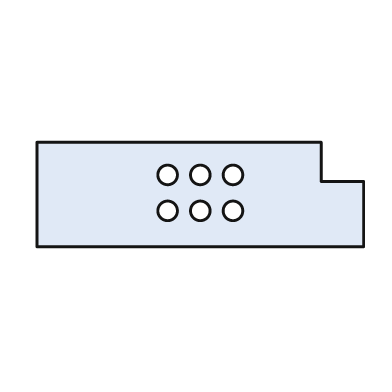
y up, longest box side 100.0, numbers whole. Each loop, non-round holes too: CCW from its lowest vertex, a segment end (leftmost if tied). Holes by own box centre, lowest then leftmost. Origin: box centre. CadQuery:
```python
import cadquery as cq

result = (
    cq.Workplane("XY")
    .moveTo(-50.0, -16.0)
    .lineTo(50.0, -16.0)
    .lineTo(50.0, 4.0)
    .lineTo(37.0, 4.0)
    .lineTo(37.0, 16.0)
    .lineTo(-50.0, 16.0)
    .close()
    .moveTo(-10.0, -5.0)
    .circle(3.0)
    .moveTo(0.0, -5.0)
    .circle(3.0)
    .moveTo(10.0, -5.0)
    .circle(3.0)
    .moveTo(-10.0, 6.0)
    .circle(3.0)
    .moveTo(0.0, 6.0)
    .circle(3.0)
    .moveTo(10.0, 6.0)
    .circle(3.0)
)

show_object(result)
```